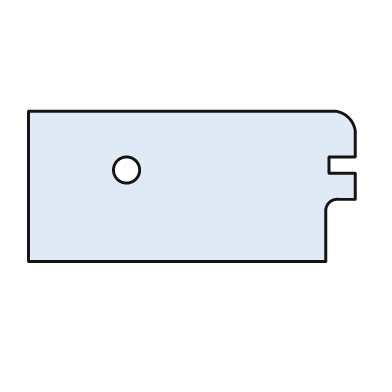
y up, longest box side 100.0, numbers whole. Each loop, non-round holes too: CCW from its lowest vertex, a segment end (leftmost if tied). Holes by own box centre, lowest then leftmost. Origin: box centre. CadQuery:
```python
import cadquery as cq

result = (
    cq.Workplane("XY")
    .moveTo(-50.0, -23.0)
    .lineTo(41.0, -23.0)
    .lineTo(41.0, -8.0)
    .threePointArc((42.0, -5.0), (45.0, -4.0))
    .lineTo(50.0, -4.0)
    .lineTo(50.0, 4.0)
    .lineTo(42.0, 4.0)
    .lineTo(42.0, 9.0)
    .lineTo(50.0, 9.0)
    .lineTo(50.0, 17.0)
    .threePointArc((48.0, 21.0), (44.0, 23.0))
    .lineTo(-50.0, 23.0)
    .close()
    .moveTo(-20.0, 5.0)
    .circle(4.0)
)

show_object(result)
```